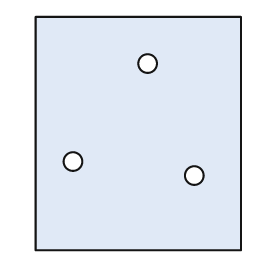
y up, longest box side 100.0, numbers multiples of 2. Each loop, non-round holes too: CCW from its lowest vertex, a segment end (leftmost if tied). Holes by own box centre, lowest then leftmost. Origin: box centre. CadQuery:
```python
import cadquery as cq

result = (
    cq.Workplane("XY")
    .moveTo(-44.0, -50.0)
    .lineTo(44.0, -50.0)
    .lineTo(44.0, 50.0)
    .lineTo(-44.0, 50.0)
    .close()
    .moveTo(24.0, -18.0)
    .circle(4.0)
    .moveTo(-28.0, -12.0)
    .circle(4.0)
    .moveTo(4.0, 30.0)
    .circle(4.0)
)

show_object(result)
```